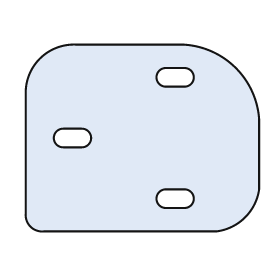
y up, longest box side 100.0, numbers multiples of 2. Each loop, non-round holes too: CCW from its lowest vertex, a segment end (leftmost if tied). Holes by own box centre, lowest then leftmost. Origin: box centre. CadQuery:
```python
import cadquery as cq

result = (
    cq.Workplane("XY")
    .moveTo(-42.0, -40.0)
    .lineTo(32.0, -40.0)
    .threePointArc((44.0, -34.0), (50.0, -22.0))
    .lineTo(50.0, 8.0)
    .threePointArc((40.0, 30.0), (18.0, 40.0))
    .lineTo(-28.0, 40.0)
    .threePointArc((-44.0, 34.0), (-50.0, 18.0))
    .lineTo(-50.0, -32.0)
    .threePointArc((-48.0, -38.0), (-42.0, -40.0))
    .close()
    .moveTo(10.0, -30.0)
    .lineTo(18.0, -30.0)
    .threePointArc((22.0, -26.0), (18.0, -22.0))
    .lineTo(10.0, -22.0)
    .threePointArc((6.0, -26.0), (10.0, -30.0))
    .close()
    .moveTo(-34.0, -4.0)
    .lineTo(-26.0, -4.0)
    .threePointArc((-22.0, 0.0), (-26.0, 4.0))
    .lineTo(-34.0, 4.0)
    .threePointArc((-38.0, 0.0), (-34.0, -4.0))
    .close()
    .moveTo(10.0, 22.0)
    .lineTo(18.0, 22.0)
    .threePointArc((22.0, 26.0), (18.0, 30.0))
    .lineTo(10.0, 30.0)
    .threePointArc((6.0, 26.0), (10.0, 22.0))
    .close()
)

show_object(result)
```